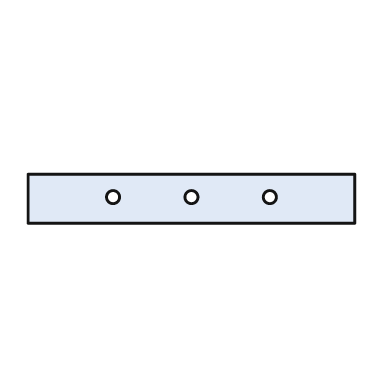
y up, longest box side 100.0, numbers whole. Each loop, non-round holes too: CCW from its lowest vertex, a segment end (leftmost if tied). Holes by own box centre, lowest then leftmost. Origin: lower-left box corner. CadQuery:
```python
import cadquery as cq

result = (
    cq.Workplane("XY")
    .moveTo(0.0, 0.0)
    .lineTo(100.0, 0.0)
    .lineTo(100.0, 15.0)
    .lineTo(0.0, 15.0)
    .close()
    .moveTo(26.0, 8.0)
    .circle(2.0)
    .moveTo(50.0, 8.0)
    .circle(2.0)
    .moveTo(74.0, 8.0)
    .circle(2.0)
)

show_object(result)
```